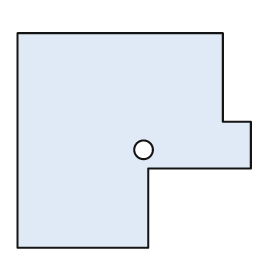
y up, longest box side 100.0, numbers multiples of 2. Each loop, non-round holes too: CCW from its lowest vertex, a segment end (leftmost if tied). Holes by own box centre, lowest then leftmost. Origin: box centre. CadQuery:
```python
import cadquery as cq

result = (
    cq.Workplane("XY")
    .moveTo(-50.0, -46.0)
    .lineTo(6.0, -46.0)
    .lineTo(6.0, -12.0)
    .lineTo(50.0, -12.0)
    .lineTo(50.0, 8.0)
    .lineTo(38.0, 8.0)
    .lineTo(38.0, 46.0)
    .lineTo(-50.0, 46.0)
    .close()
    .moveTo(4.0, -4.0)
    .circle(4.0)
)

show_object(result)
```